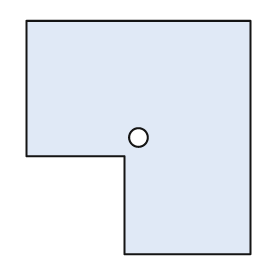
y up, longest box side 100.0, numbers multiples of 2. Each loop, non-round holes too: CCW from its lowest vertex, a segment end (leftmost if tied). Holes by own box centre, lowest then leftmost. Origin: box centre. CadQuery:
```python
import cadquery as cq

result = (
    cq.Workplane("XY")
    .moveTo(-6.0, -50.0)
    .lineTo(48.0, -50.0)
    .lineTo(48.0, 50.0)
    .lineTo(-48.0, 50.0)
    .lineTo(-48.0, -8.0)
    .lineTo(-6.0, -8.0)
    .close()
    .moveTo(0.0, 0.0)
    .circle(4.0)
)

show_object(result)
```